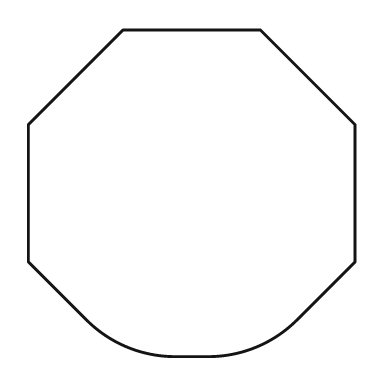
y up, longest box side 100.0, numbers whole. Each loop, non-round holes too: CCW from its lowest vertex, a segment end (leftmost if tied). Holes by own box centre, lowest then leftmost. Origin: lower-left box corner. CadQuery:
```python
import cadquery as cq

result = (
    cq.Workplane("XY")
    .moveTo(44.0, 0.0)
    .lineTo(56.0, 0.0)
    .threePointArc((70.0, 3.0), (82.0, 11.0))
    .lineTo(100.0, 29.0)
    .lineTo(100.0, 71.0)
    .lineTo(71.0, 100.0)
    .lineTo(29.0, 100.0)
    .lineTo(0.0, 71.0)
    .lineTo(0.0, 29.0)
    .lineTo(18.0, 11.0)
    .threePointArc((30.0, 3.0), (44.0, 0.0))
    .close()
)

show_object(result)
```